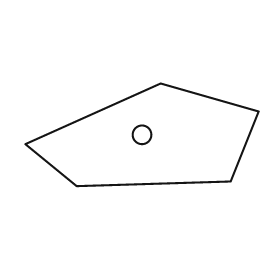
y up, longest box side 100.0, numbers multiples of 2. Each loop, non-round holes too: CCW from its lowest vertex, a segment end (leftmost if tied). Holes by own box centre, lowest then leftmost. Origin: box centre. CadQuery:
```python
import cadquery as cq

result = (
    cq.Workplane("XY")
    .moveTo(-28.0, -22.0)
    .lineTo(38.0, -20.0)
    .lineTo(50.0, 10.0)
    .lineTo(8.0, 22.0)
    .lineTo(-50.0, -4.0)
    .close()
    .moveTo(0.0, 0.0)
    .circle(4.0)
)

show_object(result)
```